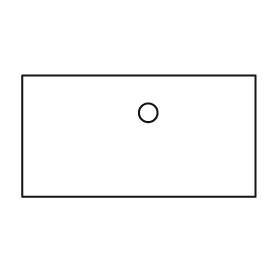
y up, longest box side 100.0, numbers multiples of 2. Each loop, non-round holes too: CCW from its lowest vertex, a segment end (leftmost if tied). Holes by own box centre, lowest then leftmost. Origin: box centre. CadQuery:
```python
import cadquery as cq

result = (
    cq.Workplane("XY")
    .moveTo(-50.0, -26.0)
    .lineTo(50.0, -26.0)
    .lineTo(50.0, 26.0)
    .lineTo(-50.0, 26.0)
    .close()
    .moveTo(4.0, 10.0)
    .circle(4.0)
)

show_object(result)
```